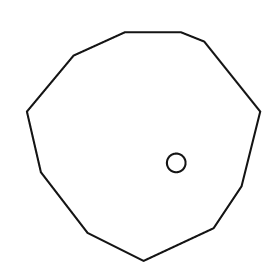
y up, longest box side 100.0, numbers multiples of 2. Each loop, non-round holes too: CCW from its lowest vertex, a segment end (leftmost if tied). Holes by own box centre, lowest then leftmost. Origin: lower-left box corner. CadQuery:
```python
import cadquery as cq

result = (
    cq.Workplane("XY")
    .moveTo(50.0, 0.0)
    .lineTo(80.0, 14.0)
    .lineTo(92.0, 32.0)
    .lineTo(100.0, 64.0)
    .lineTo(76.0, 94.0)
    .lineTo(66.0, 98.0)
    .lineTo(42.0, 98.0)
    .lineTo(20.0, 88.0)
    .lineTo(0.0, 64.0)
    .lineTo(6.0, 38.0)
    .lineTo(26.0, 12.0)
    .close()
    .moveTo(64.0, 42.0)
    .circle(4.0)
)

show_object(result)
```